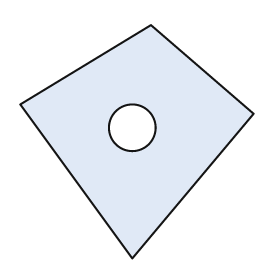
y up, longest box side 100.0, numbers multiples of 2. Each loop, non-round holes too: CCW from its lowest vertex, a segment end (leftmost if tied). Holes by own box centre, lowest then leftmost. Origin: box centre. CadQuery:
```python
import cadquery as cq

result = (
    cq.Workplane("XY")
    .moveTo(-2.0, -50.0)
    .lineTo(50.0, 12.0)
    .lineTo(6.0, 50.0)
    .lineTo(-50.0, 16.0)
    .close()
    .moveTo(-2.0, 6.0)
    .circle(10.0)
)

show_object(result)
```